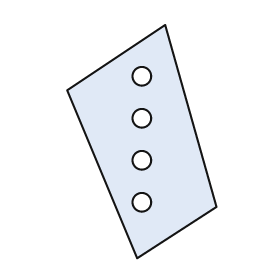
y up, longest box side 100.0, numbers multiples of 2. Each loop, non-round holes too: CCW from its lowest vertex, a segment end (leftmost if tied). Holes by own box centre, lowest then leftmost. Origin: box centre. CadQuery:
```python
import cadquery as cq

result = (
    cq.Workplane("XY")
    .moveTo(-2.0, -50.0)
    .lineTo(32.0, -28.0)
    .lineTo(10.0, 50.0)
    .lineTo(-32.0, 22.0)
    .close()
    .moveTo(0.0, -26.0)
    .circle(4.0)
    .moveTo(0.0, -8.0)
    .circle(4.0)
    .moveTo(0.0, 10.0)
    .circle(4.0)
    .moveTo(0.0, 28.0)
    .circle(4.0)
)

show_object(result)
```